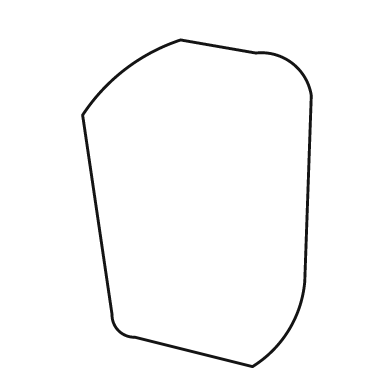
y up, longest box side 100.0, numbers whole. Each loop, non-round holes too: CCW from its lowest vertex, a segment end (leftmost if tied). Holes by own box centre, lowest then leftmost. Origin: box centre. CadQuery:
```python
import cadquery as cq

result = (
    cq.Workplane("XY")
    .moveTo(17.0, -50.0)
    .threePointArc((28.0, -39.0), (33.0, -24.0))
    .lineTo(35.0, 33.0)
    .threePointArc((29.0, 43.0), (18.0, 46.0))
    .lineTo(-5.0, 50.0)
    .threePointArc((-22.0, 41.0), (-35.0, 27.0))
    .lineTo(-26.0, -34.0)
    .threePointArc((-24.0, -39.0), (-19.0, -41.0))
    .close()
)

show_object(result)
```